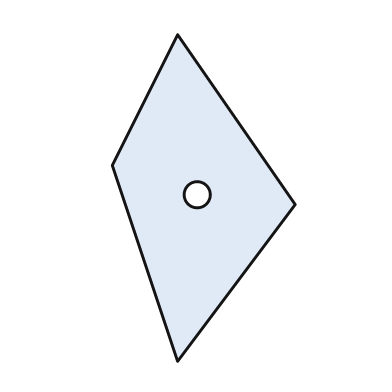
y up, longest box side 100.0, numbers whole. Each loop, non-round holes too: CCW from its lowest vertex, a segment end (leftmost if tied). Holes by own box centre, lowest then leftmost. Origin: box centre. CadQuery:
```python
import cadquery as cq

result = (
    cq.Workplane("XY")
    .moveTo(-8.0, -50.0)
    .lineTo(28.0, -2.0)
    .lineTo(-8.0, 50.0)
    .lineTo(-28.0, 10.0)
    .close()
    .moveTo(-2.0, 1.0)
    .circle(4.0)
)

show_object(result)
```